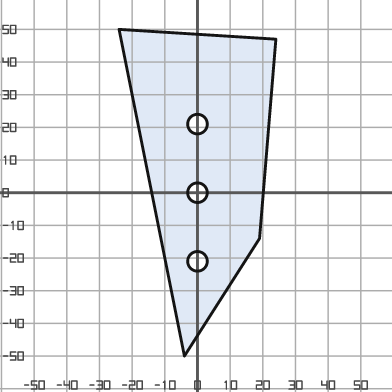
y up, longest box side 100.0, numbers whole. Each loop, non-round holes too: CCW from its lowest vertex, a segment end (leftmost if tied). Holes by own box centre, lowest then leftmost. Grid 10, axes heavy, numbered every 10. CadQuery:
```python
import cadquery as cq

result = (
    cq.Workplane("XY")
    .moveTo(-4.0, -50.0)
    .lineTo(19.0, -14.0)
    .lineTo(24.0, 47.0)
    .lineTo(-24.0, 50.0)
    .close()
    .moveTo(0.0, -21.0)
    .circle(3.0)
    .moveTo(0.0, 0.0)
    .circle(3.0)
    .moveTo(0.0, 21.0)
    .circle(3.0)
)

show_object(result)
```